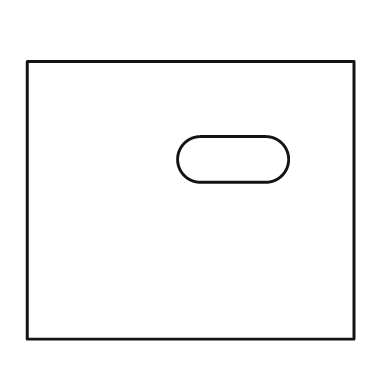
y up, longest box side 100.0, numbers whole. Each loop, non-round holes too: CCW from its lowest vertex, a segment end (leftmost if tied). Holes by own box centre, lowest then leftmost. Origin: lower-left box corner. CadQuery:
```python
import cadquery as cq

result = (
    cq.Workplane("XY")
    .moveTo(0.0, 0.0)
    .lineTo(100.0, 0.0)
    .lineTo(100.0, 85.0)
    .lineTo(0.0, 85.0)
    .close()
    .moveTo(53.0, 48.0)
    .lineTo(73.0, 48.0)
    .threePointArc((80.0, 55.0), (73.0, 62.0))
    .lineTo(53.0, 62.0)
    .threePointArc((46.0, 55.0), (53.0, 48.0))
    .close()
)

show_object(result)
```